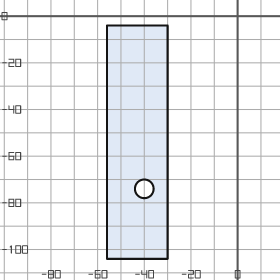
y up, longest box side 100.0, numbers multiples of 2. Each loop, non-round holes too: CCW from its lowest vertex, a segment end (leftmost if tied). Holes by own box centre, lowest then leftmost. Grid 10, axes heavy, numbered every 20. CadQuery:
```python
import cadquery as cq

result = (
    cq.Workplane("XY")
    .moveTo(-56.0, -104.0)
    .lineTo(-30.0, -104.0)
    .lineTo(-30.0, -4.0)
    .lineTo(-56.0, -4.0)
    .close()
    .moveTo(-40.0, -74.0)
    .circle(4.0)
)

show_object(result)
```